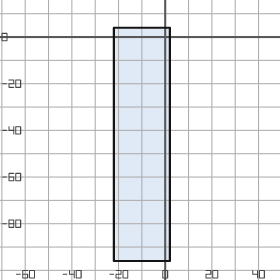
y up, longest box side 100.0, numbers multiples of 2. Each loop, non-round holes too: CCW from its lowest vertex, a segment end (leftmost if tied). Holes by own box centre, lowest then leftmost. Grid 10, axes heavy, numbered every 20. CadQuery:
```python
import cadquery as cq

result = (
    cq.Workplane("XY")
    .moveTo(-22.0, -96.0)
    .lineTo(2.0, -96.0)
    .lineTo(2.0, 4.0)
    .lineTo(-22.0, 4.0)
    .close()
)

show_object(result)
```